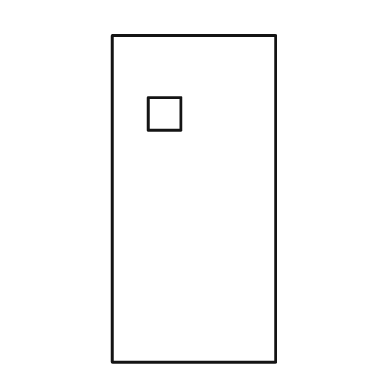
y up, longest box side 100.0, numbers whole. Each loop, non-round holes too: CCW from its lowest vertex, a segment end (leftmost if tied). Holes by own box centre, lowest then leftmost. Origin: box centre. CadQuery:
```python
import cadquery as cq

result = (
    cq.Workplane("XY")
    .moveTo(-25.0, -50.0)
    .lineTo(25.0, -50.0)
    .lineTo(25.0, 50.0)
    .lineTo(-25.0, 50.0)
    .close()
    .moveTo(-14.0, 21.0)
    .lineTo(-4.0, 21.0)
    .lineTo(-4.0, 31.0)
    .lineTo(-14.0, 31.0)
    .close()
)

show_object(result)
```